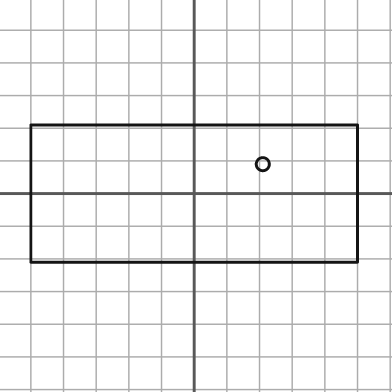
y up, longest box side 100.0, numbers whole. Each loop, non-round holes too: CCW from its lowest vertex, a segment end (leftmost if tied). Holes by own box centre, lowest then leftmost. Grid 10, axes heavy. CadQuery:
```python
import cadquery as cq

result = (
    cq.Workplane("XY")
    .moveTo(-50.0, -21.0)
    .lineTo(50.0, -21.0)
    .lineTo(50.0, 21.0)
    .lineTo(-50.0, 21.0)
    .close()
    .moveTo(21.0, 9.0)
    .circle(2.0)
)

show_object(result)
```